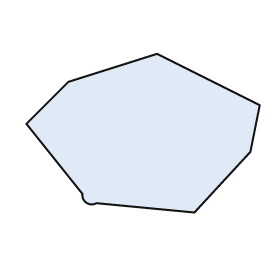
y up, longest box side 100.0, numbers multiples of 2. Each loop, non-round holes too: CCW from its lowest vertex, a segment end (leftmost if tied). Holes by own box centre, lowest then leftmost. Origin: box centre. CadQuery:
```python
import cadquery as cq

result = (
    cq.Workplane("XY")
    .moveTo(22.0, -34.0)
    .lineTo(46.0, -8.0)
    .lineTo(50.0, 12.0)
    .lineTo(6.0, 34.0)
    .lineTo(-32.0, 22.0)
    .lineTo(-50.0, 4.0)
    .lineTo(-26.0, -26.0)
    .threePointArc((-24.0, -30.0), (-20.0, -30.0))
    .close()
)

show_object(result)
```